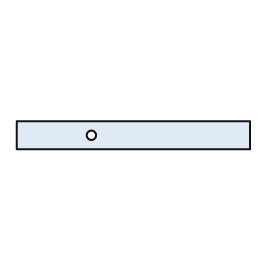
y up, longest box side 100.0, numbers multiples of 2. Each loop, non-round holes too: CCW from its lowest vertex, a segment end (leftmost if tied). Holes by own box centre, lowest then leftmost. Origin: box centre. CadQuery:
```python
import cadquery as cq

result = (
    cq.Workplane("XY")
    .moveTo(-50.0, -6.0)
    .lineTo(50.0, -6.0)
    .lineTo(50.0, 6.0)
    .lineTo(-50.0, 6.0)
    .close()
    .moveTo(-18.0, 0.0)
    .circle(2.0)
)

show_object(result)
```